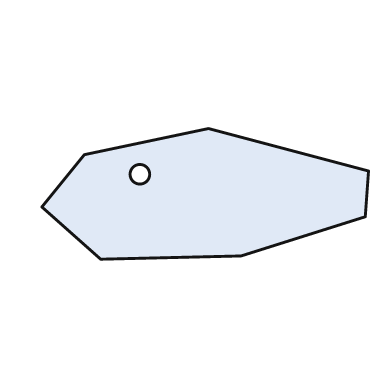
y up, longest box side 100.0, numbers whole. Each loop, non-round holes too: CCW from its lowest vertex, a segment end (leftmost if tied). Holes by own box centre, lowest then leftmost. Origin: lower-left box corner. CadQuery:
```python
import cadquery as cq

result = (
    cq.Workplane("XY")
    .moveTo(18.0, 0.0)
    .lineTo(61.0, 1.0)
    .lineTo(99.0, 13.0)
    .lineTo(100.0, 27.0)
    .lineTo(51.0, 40.0)
    .lineTo(13.0, 32.0)
    .lineTo(0.0, 16.0)
    .close()
    .moveTo(30.0, 26.0)
    .circle(3.0)
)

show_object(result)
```